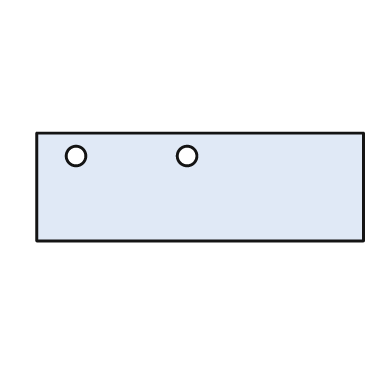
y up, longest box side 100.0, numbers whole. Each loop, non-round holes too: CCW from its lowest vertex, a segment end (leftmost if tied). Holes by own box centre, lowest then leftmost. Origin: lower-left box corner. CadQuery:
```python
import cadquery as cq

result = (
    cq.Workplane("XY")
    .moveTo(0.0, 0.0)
    .lineTo(100.0, 0.0)
    .lineTo(100.0, 33.0)
    .lineTo(0.0, 33.0)
    .close()
    .moveTo(12.0, 26.0)
    .circle(3.0)
    .moveTo(46.0, 26.0)
    .circle(3.0)
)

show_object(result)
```